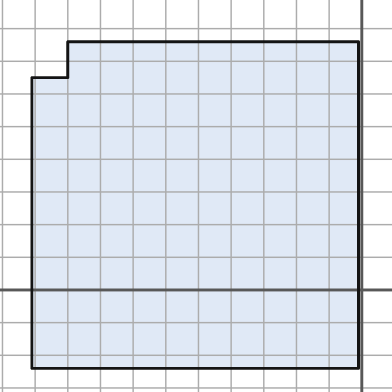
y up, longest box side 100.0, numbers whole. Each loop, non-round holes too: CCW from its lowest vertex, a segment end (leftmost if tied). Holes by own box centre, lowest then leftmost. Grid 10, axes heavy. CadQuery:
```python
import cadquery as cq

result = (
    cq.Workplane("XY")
    .moveTo(-101.0, -24.0)
    .lineTo(-1.0, -24.0)
    .lineTo(-1.0, 76.0)
    .lineTo(-90.0, 76.0)
    .lineTo(-90.0, 65.0)
    .lineTo(-101.0, 65.0)
    .close()
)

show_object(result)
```